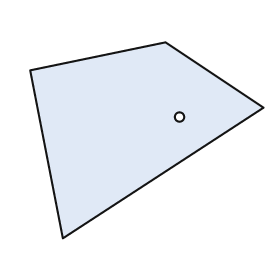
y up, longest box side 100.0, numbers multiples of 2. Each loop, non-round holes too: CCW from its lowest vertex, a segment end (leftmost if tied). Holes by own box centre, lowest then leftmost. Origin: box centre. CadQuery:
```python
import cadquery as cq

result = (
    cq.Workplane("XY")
    .moveTo(-36.0, -42.0)
    .lineTo(50.0, 14.0)
    .lineTo(8.0, 42.0)
    .lineTo(-50.0, 30.0)
    .close()
    .moveTo(14.0, 10.0)
    .circle(2.0)
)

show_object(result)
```